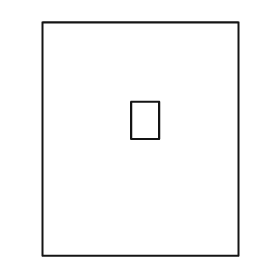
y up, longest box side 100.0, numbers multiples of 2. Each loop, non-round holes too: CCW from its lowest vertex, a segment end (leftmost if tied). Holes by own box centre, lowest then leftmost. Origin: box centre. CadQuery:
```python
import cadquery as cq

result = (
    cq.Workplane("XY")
    .moveTo(-42.0, -50.0)
    .lineTo(42.0, -50.0)
    .lineTo(42.0, 50.0)
    .lineTo(-42.0, 50.0)
    .close()
    .moveTo(-4.0, 0.0)
    .lineTo(8.0, 0.0)
    .lineTo(8.0, 16.0)
    .lineTo(-4.0, 16.0)
    .close()
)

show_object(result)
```